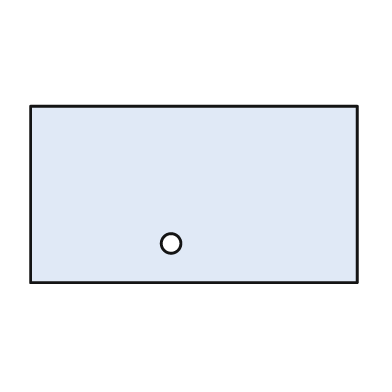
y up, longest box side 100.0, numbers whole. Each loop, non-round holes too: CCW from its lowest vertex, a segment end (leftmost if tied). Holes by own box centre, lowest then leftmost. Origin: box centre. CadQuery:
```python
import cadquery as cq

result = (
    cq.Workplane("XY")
    .moveTo(-50.0, -27.0)
    .lineTo(50.0, -27.0)
    .lineTo(50.0, 27.0)
    .lineTo(-50.0, 27.0)
    .close()
    .moveTo(-7.0, -15.0)
    .circle(3.0)
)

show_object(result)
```